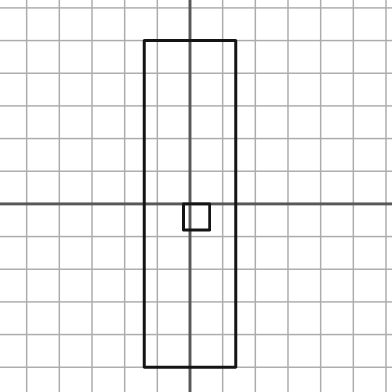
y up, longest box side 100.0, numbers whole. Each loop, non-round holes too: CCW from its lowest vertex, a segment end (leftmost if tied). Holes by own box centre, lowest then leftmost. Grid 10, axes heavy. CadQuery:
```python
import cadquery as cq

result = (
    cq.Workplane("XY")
    .moveTo(-14.0, -50.0)
    .lineTo(14.0, -50.0)
    .lineTo(14.0, 50.0)
    .lineTo(-14.0, 50.0)
    .close()
    .moveTo(-2.0, -8.0)
    .lineTo(6.0, -8.0)
    .lineTo(6.0, 0.0)
    .lineTo(-2.0, 0.0)
    .close()
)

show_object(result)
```